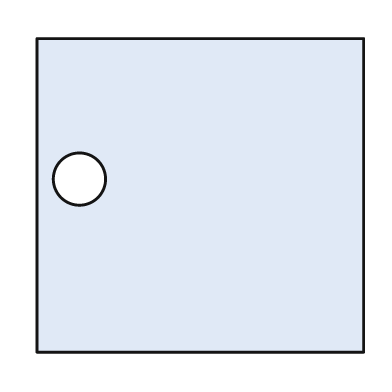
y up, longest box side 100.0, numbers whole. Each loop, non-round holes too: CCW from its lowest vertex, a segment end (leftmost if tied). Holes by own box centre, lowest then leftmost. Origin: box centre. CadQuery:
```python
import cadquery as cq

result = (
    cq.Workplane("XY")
    .moveTo(-50.0, -48.0)
    .lineTo(50.0, -48.0)
    .lineTo(50.0, 48.0)
    .lineTo(-50.0, 48.0)
    .close()
    .moveTo(-37.0, 5.0)
    .circle(8.0)
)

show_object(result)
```